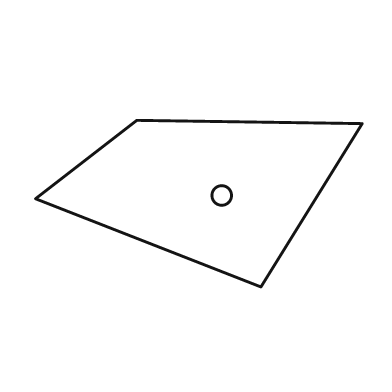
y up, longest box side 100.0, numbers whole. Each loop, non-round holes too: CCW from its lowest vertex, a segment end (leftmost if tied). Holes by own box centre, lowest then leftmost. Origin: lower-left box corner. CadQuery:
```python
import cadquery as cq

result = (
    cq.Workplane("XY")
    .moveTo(69.0, 0.0)
    .lineTo(100.0, 50.0)
    .lineTo(31.0, 51.0)
    .lineTo(0.0, 27.0)
    .close()
    .moveTo(57.0, 28.0)
    .circle(3.0)
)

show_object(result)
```